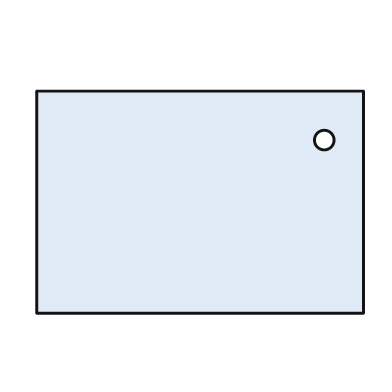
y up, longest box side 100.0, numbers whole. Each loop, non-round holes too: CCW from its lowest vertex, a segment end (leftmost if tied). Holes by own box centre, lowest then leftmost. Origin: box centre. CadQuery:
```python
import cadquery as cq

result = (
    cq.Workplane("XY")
    .moveTo(-50.0, -34.0)
    .lineTo(50.0, -34.0)
    .lineTo(50.0, 34.0)
    .lineTo(-50.0, 34.0)
    .close()
    .moveTo(38.0, 19.0)
    .circle(3.0)
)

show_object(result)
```